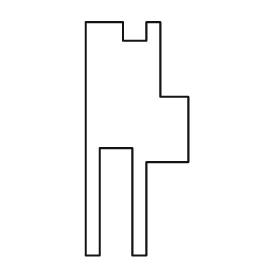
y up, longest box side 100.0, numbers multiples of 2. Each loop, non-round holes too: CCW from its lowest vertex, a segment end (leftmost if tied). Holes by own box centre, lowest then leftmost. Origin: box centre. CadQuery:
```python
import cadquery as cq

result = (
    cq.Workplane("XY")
    .moveTo(-22.0, -50.0)
    .lineTo(-16.0, -50.0)
    .lineTo(-16.0, -4.0)
    .lineTo(-2.0, -4.0)
    .lineTo(-2.0, -50.0)
    .lineTo(4.0, -50.0)
    .lineTo(4.0, -10.0)
    .lineTo(22.0, -10.0)
    .lineTo(22.0, 18.0)
    .lineTo(10.0, 18.0)
    .lineTo(10.0, 50.0)
    .lineTo(4.0, 50.0)
    .lineTo(4.0, 42.0)
    .lineTo(-6.0, 42.0)
    .lineTo(-6.0, 50.0)
    .lineTo(-22.0, 50.0)
    .close()
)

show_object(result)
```